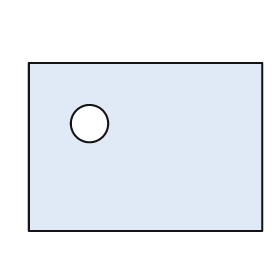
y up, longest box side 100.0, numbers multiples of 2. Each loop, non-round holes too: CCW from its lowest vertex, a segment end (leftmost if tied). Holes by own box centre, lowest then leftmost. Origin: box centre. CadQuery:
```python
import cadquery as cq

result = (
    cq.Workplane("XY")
    .moveTo(-50.0, -36.0)
    .lineTo(50.0, -36.0)
    .lineTo(50.0, 36.0)
    .lineTo(-50.0, 36.0)
    .close()
    .moveTo(-24.0, 10.0)
    .circle(8.0)
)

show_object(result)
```